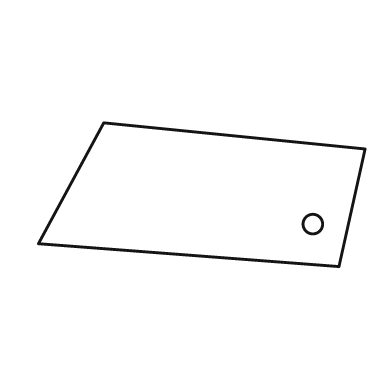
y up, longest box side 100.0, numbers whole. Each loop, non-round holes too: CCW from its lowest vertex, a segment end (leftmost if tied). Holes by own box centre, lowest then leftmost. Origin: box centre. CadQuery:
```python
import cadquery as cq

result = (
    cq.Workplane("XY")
    .moveTo(42.0, -22.0)
    .lineTo(50.0, 14.0)
    .lineTo(-30.0, 22.0)
    .lineTo(-50.0, -15.0)
    .close()
    .moveTo(34.0, -9.0)
    .circle(3.0)
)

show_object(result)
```